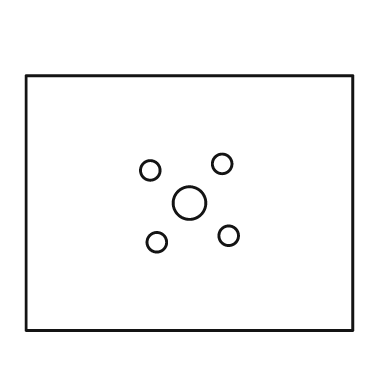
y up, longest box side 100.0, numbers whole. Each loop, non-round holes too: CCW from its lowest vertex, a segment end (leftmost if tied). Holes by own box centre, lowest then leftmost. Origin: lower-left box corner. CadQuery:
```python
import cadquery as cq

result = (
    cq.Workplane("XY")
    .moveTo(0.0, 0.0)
    .lineTo(100.0, 0.0)
    .lineTo(100.0, 78.0)
    .lineTo(0.0, 78.0)
    .close()
    .moveTo(40.0, 27.0)
    .circle(3.0)
    .moveTo(62.0, 29.0)
    .circle(3.0)
    .moveTo(50.0, 39.0)
    .circle(5.0)
    .moveTo(38.0, 49.0)
    .circle(3.0)
    .moveTo(60.0, 51.0)
    .circle(3.0)
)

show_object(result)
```